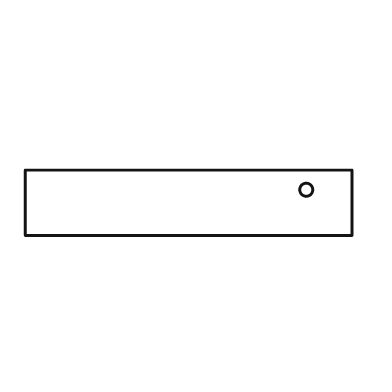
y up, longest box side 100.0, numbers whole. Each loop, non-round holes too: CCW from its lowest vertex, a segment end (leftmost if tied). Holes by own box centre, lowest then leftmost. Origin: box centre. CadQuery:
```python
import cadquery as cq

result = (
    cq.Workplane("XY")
    .moveTo(-50.0, -10.0)
    .lineTo(50.0, -10.0)
    .lineTo(50.0, 10.0)
    .lineTo(-50.0, 10.0)
    .close()
    .moveTo(36.0, 4.0)
    .circle(2.0)
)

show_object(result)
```